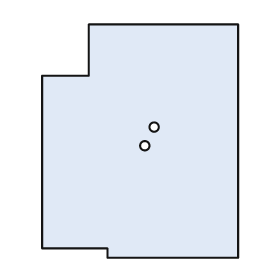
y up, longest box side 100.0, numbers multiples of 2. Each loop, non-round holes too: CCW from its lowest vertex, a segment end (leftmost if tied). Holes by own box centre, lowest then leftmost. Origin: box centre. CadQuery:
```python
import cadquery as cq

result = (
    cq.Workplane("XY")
    .moveTo(-14.0, -50.0)
    .lineTo(42.0, -50.0)
    .lineTo(42.0, 50.0)
    .lineTo(-22.0, 50.0)
    .lineTo(-22.0, 28.0)
    .lineTo(-42.0, 28.0)
    .lineTo(-42.0, -46.0)
    .lineTo(-14.0, -46.0)
    .close()
    .moveTo(2.0, -2.0)
    .circle(2.0)
    .moveTo(6.0, 6.0)
    .circle(2.0)
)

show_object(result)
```